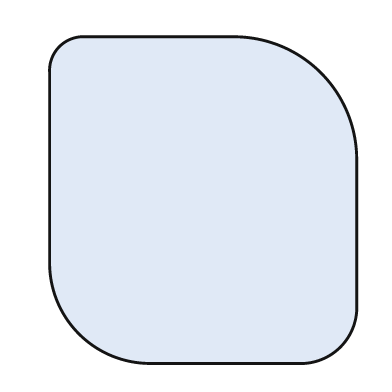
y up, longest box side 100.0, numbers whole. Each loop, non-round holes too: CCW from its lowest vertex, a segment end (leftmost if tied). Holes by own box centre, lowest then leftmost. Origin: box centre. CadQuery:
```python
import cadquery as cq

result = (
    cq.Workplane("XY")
    .moveTo(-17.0, -50.0)
    .lineTo(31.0, -50.0)
    .threePointArc((42.0, -45.0), (47.0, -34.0))
    .lineTo(47.0, 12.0)
    .threePointArc((36.0, 39.0), (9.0, 50.0))
    .lineTo(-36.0, 50.0)
    .threePointArc((-44.0, 47.0), (-47.0, 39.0))
    .lineTo(-47.0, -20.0)
    .threePointArc((-38.0, -41.0), (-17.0, -50.0))
    .close()
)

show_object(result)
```